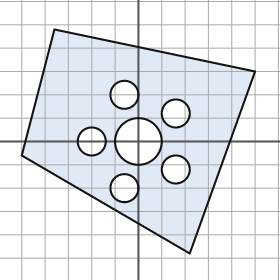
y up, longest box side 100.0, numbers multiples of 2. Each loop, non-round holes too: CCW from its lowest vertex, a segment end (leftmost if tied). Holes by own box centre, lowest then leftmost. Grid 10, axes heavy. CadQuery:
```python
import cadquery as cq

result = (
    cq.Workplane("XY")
    .moveTo(22.0, -48.0)
    .lineTo(50.0, 30.0)
    .lineTo(-36.0, 48.0)
    .lineTo(-50.0, -6.0)
    .close()
    .moveTo(-6.0, -20.0)
    .circle(6.0)
    .moveTo(16.0, -12.0)
    .circle(6.0)
    .moveTo(-20.0, 0.0)
    .circle(6.0)
    .moveTo(0.0, 0.0)
    .circle(10.0)
    .moveTo(16.0, 12.0)
    .circle(6.0)
    .moveTo(-6.0, 20.0)
    .circle(6.0)
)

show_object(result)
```